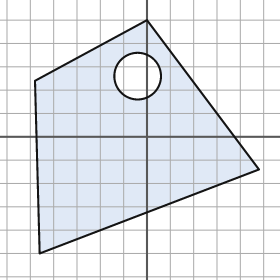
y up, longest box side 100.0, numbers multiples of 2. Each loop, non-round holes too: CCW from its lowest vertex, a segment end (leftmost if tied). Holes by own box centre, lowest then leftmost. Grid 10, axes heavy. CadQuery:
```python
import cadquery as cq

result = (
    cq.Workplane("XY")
    .moveTo(-46.0, -50.0)
    .lineTo(48.0, -14.0)
    .lineTo(0.0, 50.0)
    .lineTo(-48.0, 24.0)
    .close()
    .moveTo(-4.0, 26.0)
    .circle(10.0)
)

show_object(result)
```